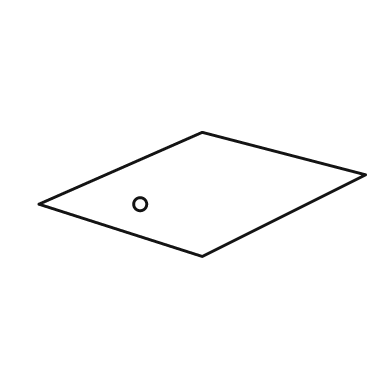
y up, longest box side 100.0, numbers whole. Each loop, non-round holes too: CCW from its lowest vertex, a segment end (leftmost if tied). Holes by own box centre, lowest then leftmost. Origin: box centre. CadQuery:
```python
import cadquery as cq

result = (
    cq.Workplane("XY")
    .moveTo(0.0, -19.0)
    .lineTo(50.0, 6.0)
    .lineTo(0.0, 19.0)
    .lineTo(-50.0, -3.0)
    .close()
    .moveTo(-19.0, -3.0)
    .circle(2.0)
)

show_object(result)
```